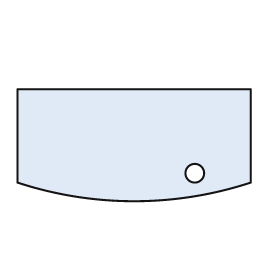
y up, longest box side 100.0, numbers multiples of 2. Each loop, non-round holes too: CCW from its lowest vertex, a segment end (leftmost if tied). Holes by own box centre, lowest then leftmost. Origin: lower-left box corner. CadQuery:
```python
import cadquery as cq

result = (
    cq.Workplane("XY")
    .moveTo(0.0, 8.0)
    .threePointArc((50.0, 0.0), (100.0, 8.0))
    .lineTo(100.0, 48.0)
    .lineTo(0.0, 48.0)
    .close()
    .moveTo(76.0, 12.0)
    .circle(4.0)
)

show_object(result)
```